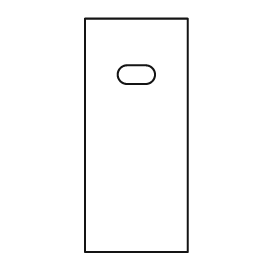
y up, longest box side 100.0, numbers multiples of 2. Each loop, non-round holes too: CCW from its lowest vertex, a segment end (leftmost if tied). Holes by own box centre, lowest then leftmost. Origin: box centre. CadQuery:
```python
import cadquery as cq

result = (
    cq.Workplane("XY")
    .moveTo(-22.0, -50.0)
    .lineTo(22.0, -50.0)
    .lineTo(22.0, 50.0)
    .lineTo(-22.0, 50.0)
    .close()
    .moveTo(-4.0, 22.0)
    .lineTo(4.0, 22.0)
    .threePointArc((8.0, 26.0), (4.0, 30.0))
    .lineTo(-4.0, 30.0)
    .threePointArc((-8.0, 26.0), (-4.0, 22.0))
    .close()
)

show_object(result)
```